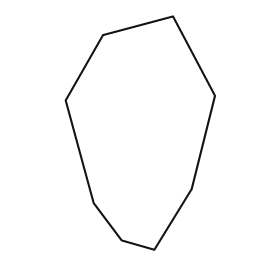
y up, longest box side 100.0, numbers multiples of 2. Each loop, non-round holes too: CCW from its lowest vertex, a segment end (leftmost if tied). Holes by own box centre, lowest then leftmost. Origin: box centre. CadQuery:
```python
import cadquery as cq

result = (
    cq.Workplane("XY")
    .moveTo(6.0, -50.0)
    .lineTo(22.0, -24.0)
    .lineTo(32.0, 16.0)
    .lineTo(14.0, 50.0)
    .lineTo(-16.0, 42.0)
    .lineTo(-32.0, 14.0)
    .lineTo(-20.0, -30.0)
    .lineTo(-8.0, -46.0)
    .close()
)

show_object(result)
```